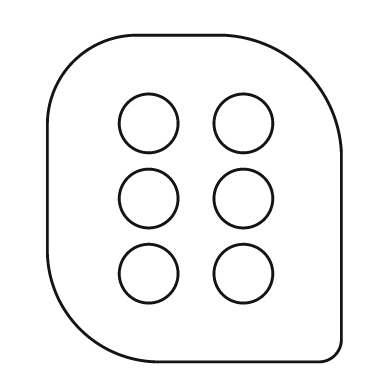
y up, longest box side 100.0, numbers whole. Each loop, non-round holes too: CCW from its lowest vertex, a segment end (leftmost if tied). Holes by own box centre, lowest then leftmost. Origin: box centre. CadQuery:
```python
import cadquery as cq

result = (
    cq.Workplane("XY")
    .moveTo(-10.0, -50.0)
    .lineTo(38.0, -50.0)
    .threePointArc((43.0, -48.0), (45.0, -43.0))
    .lineTo(45.0, 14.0)
    .threePointArc((34.0, 39.0), (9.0, 50.0))
    .lineTo(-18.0, 50.0)
    .threePointArc((-37.0, 42.0), (-45.0, 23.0))
    .lineTo(-45.0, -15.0)
    .threePointArc((-35.0, -40.0), (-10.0, -50.0))
    .close()
    .moveTo(-14.0, -23.0)
    .circle(9.0)
    .moveTo(15.0, -23.0)
    .circle(9.0)
    .moveTo(-14.0, 0.0)
    .circle(9.0)
    .moveTo(15.0, 0.0)
    .circle(9.0)
    .moveTo(-14.0, 23.0)
    .circle(9.0)
    .moveTo(15.0, 23.0)
    .circle(9.0)
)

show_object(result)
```